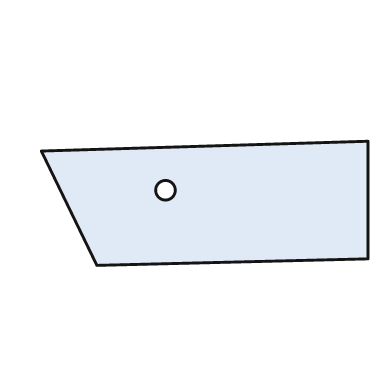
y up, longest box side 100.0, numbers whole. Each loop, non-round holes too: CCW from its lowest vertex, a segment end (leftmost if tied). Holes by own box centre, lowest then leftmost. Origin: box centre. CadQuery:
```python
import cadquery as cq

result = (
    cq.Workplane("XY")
    .moveTo(-33.0, -19.0)
    .lineTo(50.0, -17.0)
    .lineTo(50.0, 19.0)
    .lineTo(-50.0, 16.0)
    .close()
    .moveTo(-12.0, 4.0)
    .circle(3.0)
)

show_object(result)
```